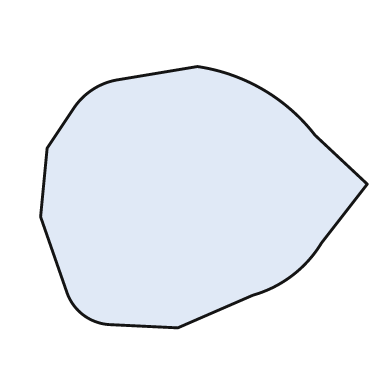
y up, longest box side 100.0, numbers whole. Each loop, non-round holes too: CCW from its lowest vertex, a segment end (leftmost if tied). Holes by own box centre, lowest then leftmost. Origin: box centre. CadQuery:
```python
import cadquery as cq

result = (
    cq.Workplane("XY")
    .moveTo(-8.0, -40.0)
    .lineTo(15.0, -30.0)
    .threePointArc((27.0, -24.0), (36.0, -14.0))
    .lineTo(50.0, 4.0)
    .lineTo(34.0, 19.0)
    .threePointArc((18.0, 33.0), (-2.0, 40.0))
    .lineTo(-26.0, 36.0)
    .threePointArc((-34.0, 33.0), (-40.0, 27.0))
    .lineTo(-48.0, 15.0)
    .lineTo(-50.0, -6.0)
    .lineTo(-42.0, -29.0)
    .threePointArc((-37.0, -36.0), (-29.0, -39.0))
    .close()
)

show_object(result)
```